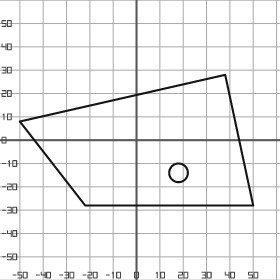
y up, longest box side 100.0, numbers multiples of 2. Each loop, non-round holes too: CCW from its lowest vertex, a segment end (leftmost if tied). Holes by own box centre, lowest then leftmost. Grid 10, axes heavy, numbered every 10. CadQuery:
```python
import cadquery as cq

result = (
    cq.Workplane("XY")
    .moveTo(-22.0, -28.0)
    .lineTo(50.0, -28.0)
    .lineTo(38.0, 28.0)
    .lineTo(-50.0, 8.0)
    .close()
    .moveTo(18.0, -14.0)
    .circle(4.0)
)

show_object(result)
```